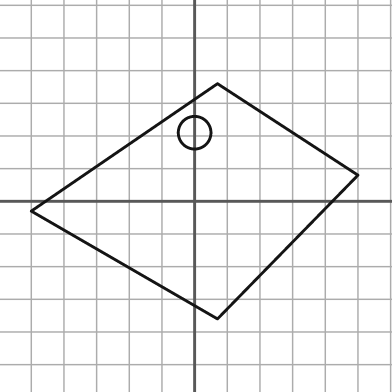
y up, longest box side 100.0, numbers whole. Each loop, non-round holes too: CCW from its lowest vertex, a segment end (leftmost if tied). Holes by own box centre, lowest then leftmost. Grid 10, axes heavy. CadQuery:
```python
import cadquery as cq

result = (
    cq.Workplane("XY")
    .moveTo(7.0, -36.0)
    .lineTo(50.0, 8.0)
    .lineTo(7.0, 36.0)
    .lineTo(-50.0, -3.0)
    .close()
    .moveTo(0.0, 21.0)
    .circle(5.0)
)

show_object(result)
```